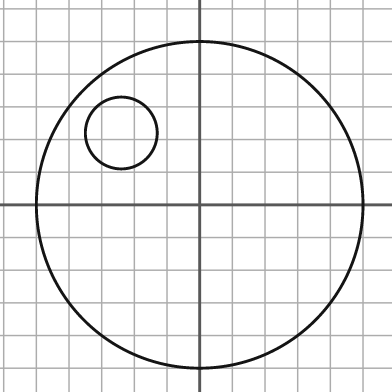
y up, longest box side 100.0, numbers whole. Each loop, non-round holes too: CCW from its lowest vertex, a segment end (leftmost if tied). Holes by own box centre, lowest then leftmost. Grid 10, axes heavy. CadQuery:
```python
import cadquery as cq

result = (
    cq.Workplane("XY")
    .moveTo(0.0, 0.0)
    .circle(50.0)
    .moveTo(-24.0, 22.0)
    .circle(11.0)
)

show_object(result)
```